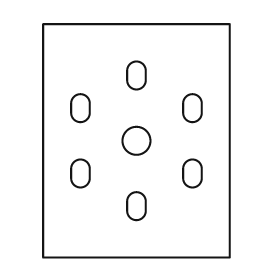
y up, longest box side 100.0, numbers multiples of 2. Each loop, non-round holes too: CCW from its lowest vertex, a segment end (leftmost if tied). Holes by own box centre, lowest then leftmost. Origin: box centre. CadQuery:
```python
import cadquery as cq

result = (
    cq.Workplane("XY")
    .moveTo(-40.0, -50.0)
    .lineTo(40.0, -50.0)
    .lineTo(40.0, 50.0)
    .lineTo(-40.0, 50.0)
    .close()
    .moveTo(-4.0, -30.0)
    .threePointArc((0.0, -34.0), (4.0, -30.0))
    .lineTo(4.0, -26.0)
    .threePointArc((0.0, -22.0), (-4.0, -26.0))
    .close()
    .moveTo(-28.0, -16.0)
    .threePointArc((-24.0, -20.0), (-20.0, -16.0))
    .lineTo(-20.0, -12.0)
    .threePointArc((-24.0, -8.0), (-28.0, -12.0))
    .close()
    .moveTo(20.0, -16.0)
    .threePointArc((24.0, -20.0), (28.0, -16.0))
    .lineTo(28.0, -12.0)
    .threePointArc((24.0, -8.0), (20.0, -12.0))
    .close()
    .moveTo(0.0, 0.0)
    .circle(6.0)
    .moveTo(-28.0, 12.0)
    .threePointArc((-24.0, 8.0), (-20.0, 12.0))
    .lineTo(-20.0, 16.0)
    .threePointArc((-24.0, 20.0), (-28.0, 16.0))
    .close()
    .moveTo(20.0, 12.0)
    .threePointArc((24.0, 8.0), (28.0, 12.0))
    .lineTo(28.0, 16.0)
    .threePointArc((24.0, 20.0), (20.0, 16.0))
    .close()
    .moveTo(-4.0, 26.0)
    .threePointArc((0.0, 22.0), (4.0, 26.0))
    .lineTo(4.0, 30.0)
    .threePointArc((0.0, 34.0), (-4.0, 30.0))
    .close()
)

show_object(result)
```